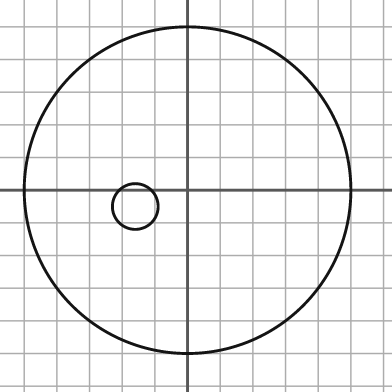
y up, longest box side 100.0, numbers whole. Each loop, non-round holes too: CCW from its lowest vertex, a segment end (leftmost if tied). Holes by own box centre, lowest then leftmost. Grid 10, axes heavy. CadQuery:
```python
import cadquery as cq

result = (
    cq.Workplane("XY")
    .moveTo(0.0, 0.0)
    .circle(50.0)
    .moveTo(-16.0, -5.0)
    .circle(7.0)
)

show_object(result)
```